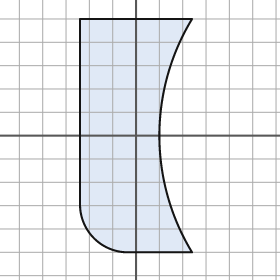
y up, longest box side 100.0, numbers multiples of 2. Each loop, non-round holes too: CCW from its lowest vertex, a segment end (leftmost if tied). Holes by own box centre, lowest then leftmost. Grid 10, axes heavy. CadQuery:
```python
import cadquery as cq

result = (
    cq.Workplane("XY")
    .moveTo(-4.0, -50.0)
    .lineTo(24.0, -50.0)
    .threePointArc((10.0, 0.0), (24.0, 50.0))
    .lineTo(-24.0, 50.0)
    .lineTo(-24.0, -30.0)
    .threePointArc((-18.0, -44.0), (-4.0, -50.0))
    .close()
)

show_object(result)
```